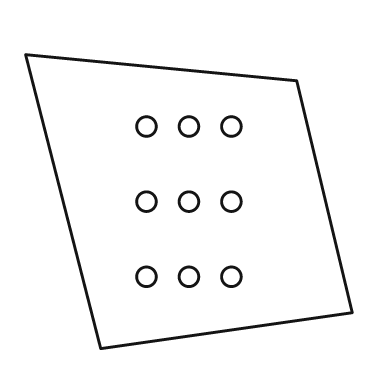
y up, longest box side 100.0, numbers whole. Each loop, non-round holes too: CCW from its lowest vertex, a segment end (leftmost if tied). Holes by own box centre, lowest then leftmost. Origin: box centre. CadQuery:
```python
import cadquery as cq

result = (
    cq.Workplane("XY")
    .moveTo(-27.0, -45.0)
    .lineTo(50.0, -34.0)
    .lineTo(33.0, 37.0)
    .lineTo(-50.0, 45.0)
    .close()
    .moveTo(-13.0, -23.0)
    .circle(3.0)
    .moveTo(0.0, -23.0)
    .circle(3.0)
    .moveTo(13.0, -23.0)
    .circle(3.0)
    .moveTo(-13.0, 0.0)
    .circle(3.0)
    .moveTo(0.0, 0.0)
    .circle(3.0)
    .moveTo(13.0, 0.0)
    .circle(3.0)
    .moveTo(-13.0, 23.0)
    .circle(3.0)
    .moveTo(0.0, 23.0)
    .circle(3.0)
    .moveTo(13.0, 23.0)
    .circle(3.0)
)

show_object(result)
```